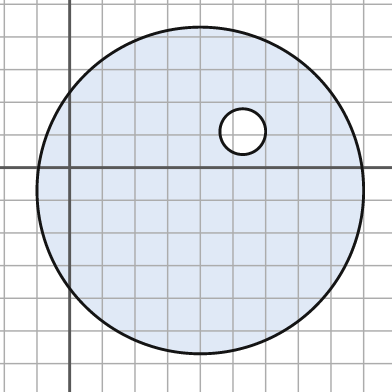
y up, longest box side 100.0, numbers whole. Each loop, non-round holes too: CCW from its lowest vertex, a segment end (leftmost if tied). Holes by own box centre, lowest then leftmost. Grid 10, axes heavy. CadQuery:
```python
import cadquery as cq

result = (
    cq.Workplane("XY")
    .moveTo(40.0, -7.0)
    .circle(50.0)
    .moveTo(53.0, 11.0)
    .circle(7.0)
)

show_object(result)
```